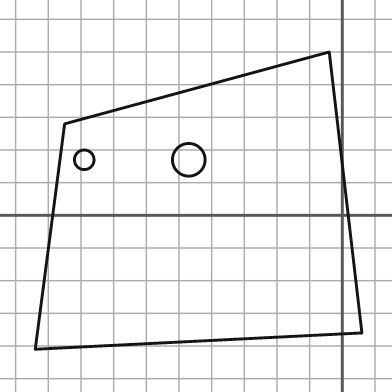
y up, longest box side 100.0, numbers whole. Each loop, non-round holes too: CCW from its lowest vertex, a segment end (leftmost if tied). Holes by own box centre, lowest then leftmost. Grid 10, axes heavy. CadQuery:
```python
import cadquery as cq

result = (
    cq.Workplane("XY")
    .moveTo(-94.0, -41.0)
    .lineTo(6.0, -36.0)
    .lineTo(-4.0, 50.0)
    .lineTo(-85.0, 28.0)
    .close()
    .moveTo(-79.0, 17.0)
    .circle(3.0)
    .moveTo(-47.0, 17.0)
    .circle(5.0)
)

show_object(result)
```